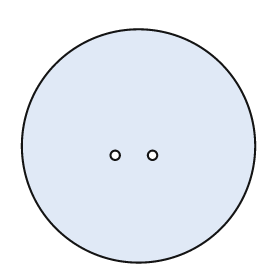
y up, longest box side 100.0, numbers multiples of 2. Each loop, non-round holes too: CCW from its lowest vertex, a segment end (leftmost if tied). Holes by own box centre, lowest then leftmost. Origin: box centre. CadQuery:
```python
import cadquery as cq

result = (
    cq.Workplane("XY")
    .moveTo(0.0, 0.0)
    .circle(50.0)
    .moveTo(-10.0, -4.0)
    .circle(2.0)
    .moveTo(6.0, -4.0)
    .circle(2.0)
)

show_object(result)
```